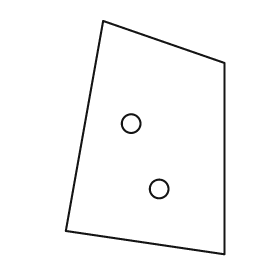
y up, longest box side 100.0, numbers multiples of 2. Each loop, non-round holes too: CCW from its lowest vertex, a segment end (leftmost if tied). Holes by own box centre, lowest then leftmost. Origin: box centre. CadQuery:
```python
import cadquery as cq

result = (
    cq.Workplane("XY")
    .moveTo(34.0, -50.0)
    .lineTo(34.0, 32.0)
    .lineTo(-18.0, 50.0)
    .lineTo(-34.0, -40.0)
    .close()
    .moveTo(6.0, -22.0)
    .circle(4.0)
    .moveTo(-6.0, 6.0)
    .circle(4.0)
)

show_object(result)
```